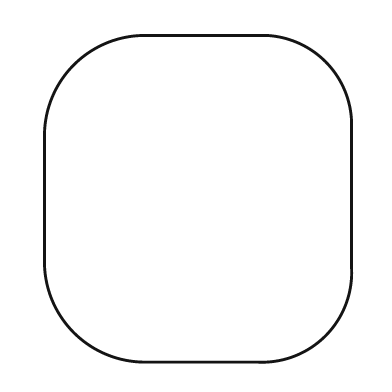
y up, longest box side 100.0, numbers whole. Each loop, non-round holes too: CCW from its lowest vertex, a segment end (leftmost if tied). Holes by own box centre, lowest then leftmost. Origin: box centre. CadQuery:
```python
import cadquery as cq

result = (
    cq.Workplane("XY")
    .moveTo(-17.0, -50.0)
    .lineTo(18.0, -50.0)
    .threePointArc((39.0, -42.0), (47.0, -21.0))
    .lineTo(47.0, 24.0)
    .threePointArc((39.0, 42.0), (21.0, 50.0))
    .lineTo(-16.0, 50.0)
    .threePointArc((-38.0, 41.0), (-47.0, 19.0))
    .lineTo(-47.0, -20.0)
    .threePointArc((-38.0, -41.0), (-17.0, -50.0))
    .close()
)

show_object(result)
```